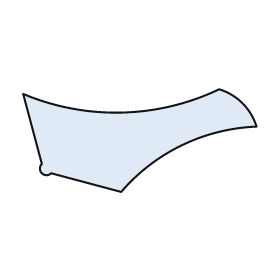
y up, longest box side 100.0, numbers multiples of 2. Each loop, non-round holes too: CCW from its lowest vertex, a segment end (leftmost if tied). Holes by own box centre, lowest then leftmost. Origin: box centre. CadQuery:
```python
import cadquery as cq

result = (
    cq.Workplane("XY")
    .moveTo(-8.0, -22.0)
    .threePointArc((18.0, -2.0), (50.0, 6.0))
    .threePointArc((44.0, 16.0), (34.0, 22.0))
    .threePointArc((-8.0, 12.0), (-50.0, 20.0))
    .lineTo(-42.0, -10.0)
    .threePointArc((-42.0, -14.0), (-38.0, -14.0))
    .close()
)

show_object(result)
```